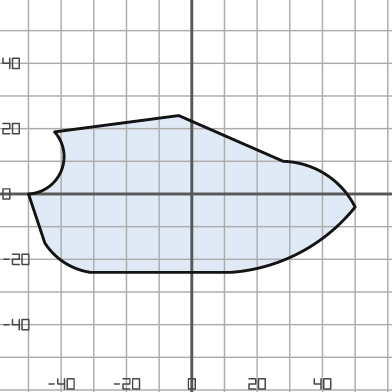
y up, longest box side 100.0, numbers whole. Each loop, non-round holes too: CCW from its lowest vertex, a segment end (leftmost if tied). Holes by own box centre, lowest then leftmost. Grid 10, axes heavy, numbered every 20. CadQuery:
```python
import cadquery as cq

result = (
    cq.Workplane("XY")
    .moveTo(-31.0, -24.0)
    .lineTo(12.0, -24.0)
    .threePointArc((33.0, -18.0), (50.0, -4.0))
    .threePointArc((41.0, 6.0), (28.0, 10.0))
    .lineTo(-4.0, 24.0)
    .lineTo(-42.0, 19.0)
    .threePointArc((-40.0, 7.0), (-50.0, 0.0))
    .lineTo(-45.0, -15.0)
    .threePointArc((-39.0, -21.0), (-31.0, -24.0))
    .close()
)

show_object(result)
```